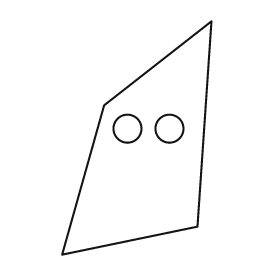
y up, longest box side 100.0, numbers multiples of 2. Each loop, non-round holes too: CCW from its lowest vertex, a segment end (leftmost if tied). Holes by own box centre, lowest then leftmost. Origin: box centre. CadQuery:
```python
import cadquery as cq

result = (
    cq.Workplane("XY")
    .moveTo(-32.0, -50.0)
    .lineTo(26.0, -38.0)
    .lineTo(32.0, 50.0)
    .lineTo(-14.0, 14.0)
    .close()
    .moveTo(-4.0, 4.0)
    .circle(6.0)
    .moveTo(14.0, 4.0)
    .circle(6.0)
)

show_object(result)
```